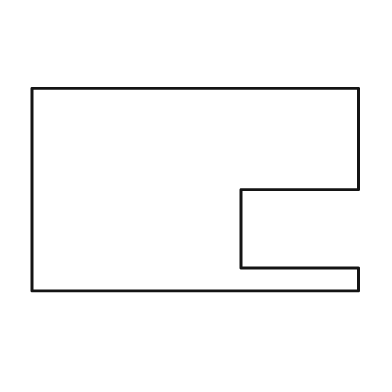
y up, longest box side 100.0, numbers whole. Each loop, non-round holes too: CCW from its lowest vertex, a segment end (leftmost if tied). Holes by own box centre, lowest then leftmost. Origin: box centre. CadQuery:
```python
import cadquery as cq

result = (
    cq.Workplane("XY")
    .moveTo(-50.0, -31.0)
    .lineTo(50.0, -31.0)
    .lineTo(50.0, -24.0)
    .lineTo(14.0, -24.0)
    .lineTo(14.0, 0.0)
    .lineTo(50.0, 0.0)
    .lineTo(50.0, 31.0)
    .lineTo(-50.0, 31.0)
    .close()
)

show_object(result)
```